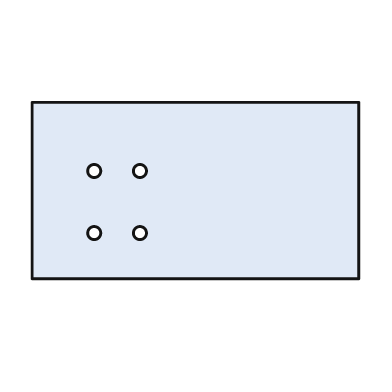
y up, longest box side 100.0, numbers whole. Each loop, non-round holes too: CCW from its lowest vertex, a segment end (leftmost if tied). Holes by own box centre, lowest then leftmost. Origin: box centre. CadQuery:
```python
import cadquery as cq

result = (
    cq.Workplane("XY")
    .moveTo(-50.0, -27.0)
    .lineTo(50.0, -27.0)
    .lineTo(50.0, 27.0)
    .lineTo(-50.0, 27.0)
    .close()
    .moveTo(-31.0, -13.0)
    .circle(2.0)
    .moveTo(-17.0, -13.0)
    .circle(2.0)
    .moveTo(-31.0, 6.0)
    .circle(2.0)
    .moveTo(-17.0, 6.0)
    .circle(2.0)
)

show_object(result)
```